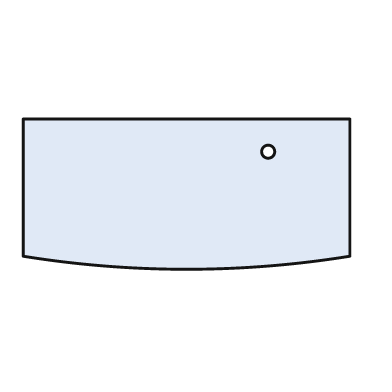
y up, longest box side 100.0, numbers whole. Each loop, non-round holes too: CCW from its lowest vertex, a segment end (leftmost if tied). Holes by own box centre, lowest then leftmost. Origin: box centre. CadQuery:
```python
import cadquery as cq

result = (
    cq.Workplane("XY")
    .moveTo(-50.0, -19.0)
    .threePointArc((0.0, -23.0), (50.0, -19.0))
    .lineTo(50.0, 23.0)
    .lineTo(-50.0, 23.0)
    .close()
    .moveTo(25.0, 13.0)
    .circle(2.0)
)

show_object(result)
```